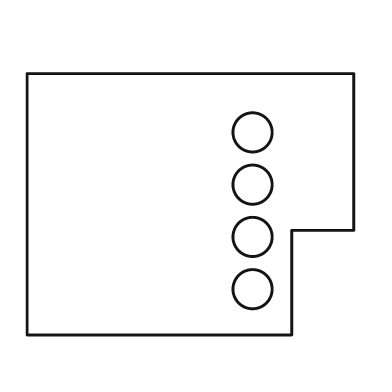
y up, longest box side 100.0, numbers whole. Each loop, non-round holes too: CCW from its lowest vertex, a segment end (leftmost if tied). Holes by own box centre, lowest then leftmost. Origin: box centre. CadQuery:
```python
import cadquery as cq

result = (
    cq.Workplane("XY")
    .moveTo(-50.0, -40.0)
    .lineTo(31.0, -40.0)
    .lineTo(31.0, -8.0)
    .lineTo(50.0, -8.0)
    .lineTo(50.0, 40.0)
    .lineTo(-50.0, 40.0)
    .close()
    .moveTo(19.0, -26.0)
    .circle(6.0)
    .moveTo(19.0, -10.0)
    .circle(6.0)
    .moveTo(19.0, 6.0)
    .circle(6.0)
    .moveTo(19.0, 22.0)
    .circle(6.0)
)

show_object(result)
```